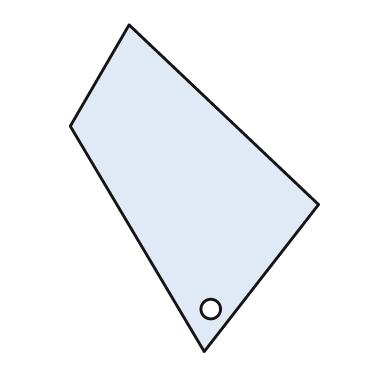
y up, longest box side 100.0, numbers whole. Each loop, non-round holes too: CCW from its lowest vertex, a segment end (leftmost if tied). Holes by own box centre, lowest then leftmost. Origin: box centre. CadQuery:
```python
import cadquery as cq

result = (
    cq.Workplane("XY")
    .moveTo(3.0, -50.0)
    .lineTo(38.0, -5.0)
    .lineTo(-20.0, 50.0)
    .lineTo(-38.0, 19.0)
    .close()
    .moveTo(5.0, -37.0)
    .circle(3.0)
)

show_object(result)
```